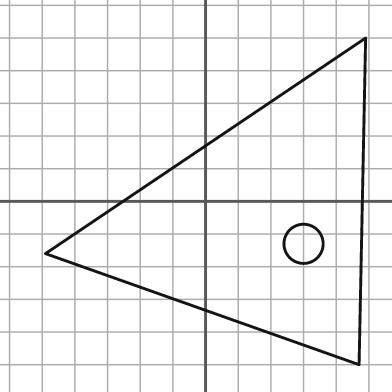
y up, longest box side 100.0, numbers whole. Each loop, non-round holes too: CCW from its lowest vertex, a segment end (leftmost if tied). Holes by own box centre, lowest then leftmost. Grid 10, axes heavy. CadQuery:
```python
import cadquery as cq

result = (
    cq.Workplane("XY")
    .moveTo(47.0, -50.0)
    .lineTo(49.0, 50.0)
    .lineTo(-49.0, -16.0)
    .close()
    .moveTo(30.0, -13.0)
    .circle(6.0)
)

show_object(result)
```